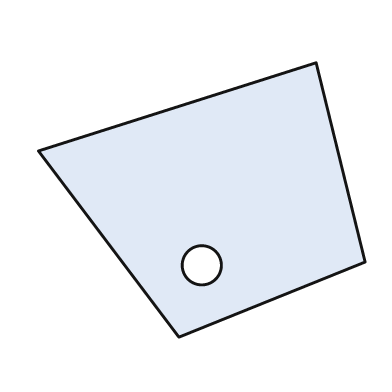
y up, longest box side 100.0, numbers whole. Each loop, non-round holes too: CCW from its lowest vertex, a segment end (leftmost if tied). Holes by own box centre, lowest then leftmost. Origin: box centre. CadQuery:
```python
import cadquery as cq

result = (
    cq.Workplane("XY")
    .moveTo(-7.0, -42.0)
    .lineTo(50.0, -19.0)
    .lineTo(35.0, 42.0)
    .lineTo(-50.0, 15.0)
    .close()
    .moveTo(0.0, -20.0)
    .circle(6.0)
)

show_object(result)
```